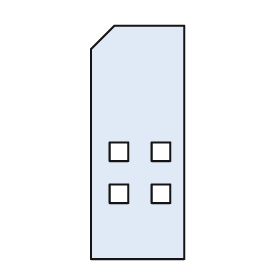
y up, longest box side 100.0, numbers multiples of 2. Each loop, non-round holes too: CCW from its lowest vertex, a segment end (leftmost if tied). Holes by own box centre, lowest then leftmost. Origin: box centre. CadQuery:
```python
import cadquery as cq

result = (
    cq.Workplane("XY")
    .moveTo(-20.0, -50.0)
    .lineTo(20.0, -50.0)
    .lineTo(20.0, 50.0)
    .lineTo(-10.0, 50.0)
    .lineTo(-20.0, 40.0)
    .close()
    .moveTo(-12.0, -26.0)
    .lineTo(-4.0, -26.0)
    .lineTo(-4.0, -18.0)
    .lineTo(-12.0, -18.0)
    .close()
    .moveTo(6.0, -26.0)
    .lineTo(14.0, -26.0)
    .lineTo(14.0, -18.0)
    .lineTo(6.0, -18.0)
    .close()
    .moveTo(-12.0, -8.0)
    .lineTo(-4.0, -8.0)
    .lineTo(-4.0, 0.0)
    .lineTo(-12.0, 0.0)
    .close()
    .moveTo(6.0, -8.0)
    .lineTo(14.0, -8.0)
    .lineTo(14.0, 0.0)
    .lineTo(6.0, 0.0)
    .close()
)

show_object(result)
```